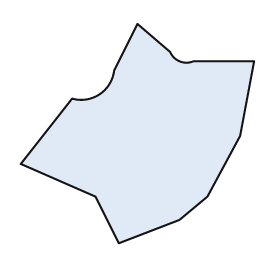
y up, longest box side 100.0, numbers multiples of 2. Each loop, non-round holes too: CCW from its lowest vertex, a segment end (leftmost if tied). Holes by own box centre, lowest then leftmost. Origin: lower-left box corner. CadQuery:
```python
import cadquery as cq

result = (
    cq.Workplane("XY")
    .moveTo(42.0, 0.0)
    .lineTo(68.0, 10.0)
    .lineTo(80.0, 20.0)
    .lineTo(94.0, 46.0)
    .lineTo(100.0, 78.0)
    .lineTo(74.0, 78.0)
    .threePointArc((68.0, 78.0), (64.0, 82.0))
    .lineTo(50.0, 94.0)
    .lineTo(40.0, 74.0)
    .threePointArc((34.0, 64.0), (22.0, 62.0))
    .lineTo(0.0, 34.0)
    .lineTo(32.0, 20.0)
    .close()
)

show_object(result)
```